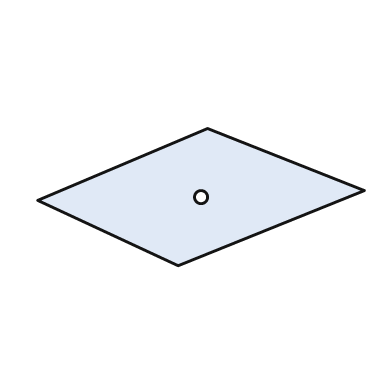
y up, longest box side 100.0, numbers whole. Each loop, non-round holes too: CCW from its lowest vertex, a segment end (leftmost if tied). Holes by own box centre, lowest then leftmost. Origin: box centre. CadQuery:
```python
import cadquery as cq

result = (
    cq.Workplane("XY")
    .moveTo(-7.0, -21.0)
    .lineTo(50.0, 2.0)
    .lineTo(2.0, 21.0)
    .lineTo(-50.0, -1.0)
    .close()
    .moveTo(0.0, 0.0)
    .circle(2.0)
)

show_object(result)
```